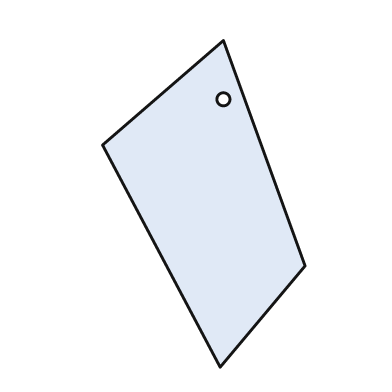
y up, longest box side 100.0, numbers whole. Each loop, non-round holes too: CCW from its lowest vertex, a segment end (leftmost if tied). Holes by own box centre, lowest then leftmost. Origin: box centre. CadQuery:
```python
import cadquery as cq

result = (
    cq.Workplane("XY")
    .moveTo(5.0, -50.0)
    .lineTo(31.0, -19.0)
    .lineTo(6.0, 50.0)
    .lineTo(-31.0, 18.0)
    .close()
    .moveTo(6.0, 32.0)
    .circle(2.0)
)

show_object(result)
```